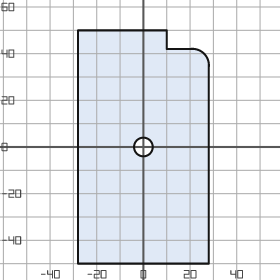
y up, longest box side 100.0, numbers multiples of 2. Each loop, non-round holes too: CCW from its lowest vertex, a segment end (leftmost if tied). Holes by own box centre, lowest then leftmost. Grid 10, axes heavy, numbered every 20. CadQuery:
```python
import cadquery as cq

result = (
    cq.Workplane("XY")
    .moveTo(-28.0, -50.0)
    .lineTo(28.0, -50.0)
    .lineTo(28.0, 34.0)
    .threePointArc((26.0, 40.0), (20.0, 42.0))
    .lineTo(10.0, 42.0)
    .lineTo(10.0, 50.0)
    .lineTo(-28.0, 50.0)
    .close()
    .moveTo(0.0, 0.0)
    .circle(4.0)
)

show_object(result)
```